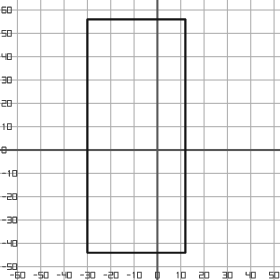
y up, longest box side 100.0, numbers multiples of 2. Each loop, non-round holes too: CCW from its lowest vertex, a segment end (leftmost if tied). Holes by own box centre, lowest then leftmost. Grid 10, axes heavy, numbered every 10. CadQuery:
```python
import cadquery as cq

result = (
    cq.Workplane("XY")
    .moveTo(-30.0, -44.0)
    .lineTo(12.0, -44.0)
    .lineTo(12.0, 56.0)
    .lineTo(-30.0, 56.0)
    .close()
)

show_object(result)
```